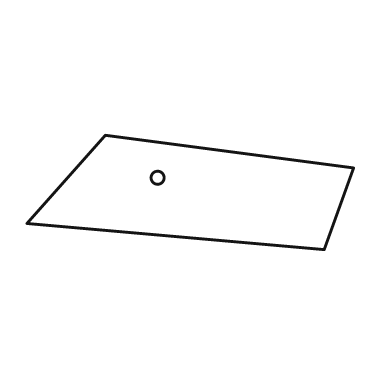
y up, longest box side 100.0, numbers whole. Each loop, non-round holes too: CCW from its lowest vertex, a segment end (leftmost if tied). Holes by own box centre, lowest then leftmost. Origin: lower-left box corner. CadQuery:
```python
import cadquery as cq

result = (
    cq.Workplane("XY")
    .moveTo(91.0, 0.0)
    .lineTo(100.0, 25.0)
    .lineTo(24.0, 35.0)
    .lineTo(0.0, 8.0)
    .close()
    .moveTo(40.0, 22.0)
    .circle(2.0)
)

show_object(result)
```